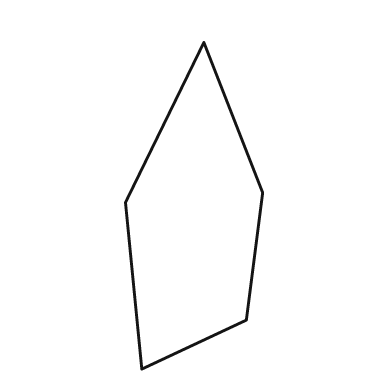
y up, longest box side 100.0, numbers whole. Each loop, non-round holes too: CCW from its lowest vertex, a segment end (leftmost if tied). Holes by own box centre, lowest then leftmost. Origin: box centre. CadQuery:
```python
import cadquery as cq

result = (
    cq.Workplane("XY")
    .moveTo(-16.0, -50.0)
    .lineTo(16.0, -35.0)
    .lineTo(21.0, 4.0)
    .lineTo(3.0, 50.0)
    .lineTo(-21.0, 1.0)
    .close()
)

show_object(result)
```